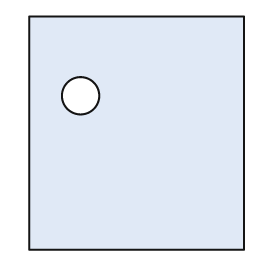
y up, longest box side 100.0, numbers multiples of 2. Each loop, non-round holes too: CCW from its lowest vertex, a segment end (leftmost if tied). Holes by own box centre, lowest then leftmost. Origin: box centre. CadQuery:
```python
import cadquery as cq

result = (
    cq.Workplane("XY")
    .moveTo(-46.0, -50.0)
    .lineTo(46.0, -50.0)
    .lineTo(46.0, 50.0)
    .lineTo(-46.0, 50.0)
    .close()
    .moveTo(-24.0, 16.0)
    .circle(8.0)
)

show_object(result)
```